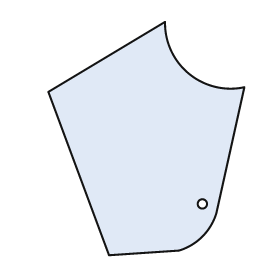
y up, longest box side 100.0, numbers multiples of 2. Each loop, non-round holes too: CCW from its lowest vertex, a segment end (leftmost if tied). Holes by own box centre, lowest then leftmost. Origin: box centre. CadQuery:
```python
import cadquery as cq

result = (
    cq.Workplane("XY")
    .moveTo(-16.0, -50.0)
    .lineTo(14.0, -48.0)
    .threePointArc((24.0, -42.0), (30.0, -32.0))
    .lineTo(42.0, 22.0)
    .threePointArc((18.0, 28.0), (8.0, 50.0))
    .lineTo(-42.0, 20.0)
    .close()
    .moveTo(24.0, -28.0)
    .circle(2.0)
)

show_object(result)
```